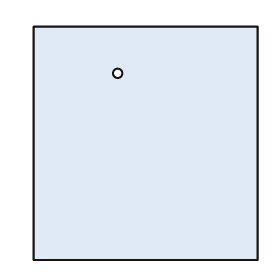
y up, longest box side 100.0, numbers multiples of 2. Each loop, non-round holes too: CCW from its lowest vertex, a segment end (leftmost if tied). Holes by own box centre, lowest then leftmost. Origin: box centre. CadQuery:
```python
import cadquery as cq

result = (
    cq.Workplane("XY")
    .moveTo(-48.0, -50.0)
    .lineTo(48.0, -50.0)
    .lineTo(48.0, 50.0)
    .lineTo(-48.0, 50.0)
    .close()
    .moveTo(-12.0, 30.0)
    .circle(2.0)
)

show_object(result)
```